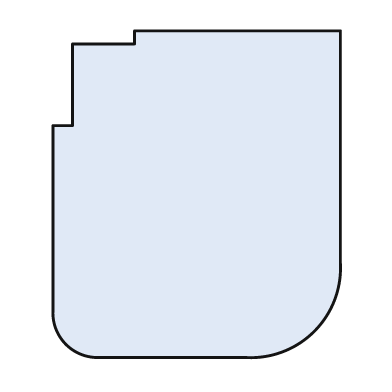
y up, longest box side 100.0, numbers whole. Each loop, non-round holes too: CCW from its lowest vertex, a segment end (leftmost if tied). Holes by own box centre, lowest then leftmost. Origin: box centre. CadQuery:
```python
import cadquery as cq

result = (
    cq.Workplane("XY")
    .moveTo(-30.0, -50.0)
    .lineTo(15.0, -50.0)
    .threePointArc((36.0, -42.0), (44.0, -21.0))
    .lineTo(44.0, 50.0)
    .lineTo(-19.0, 50.0)
    .lineTo(-19.0, 46.0)
    .lineTo(-38.0, 46.0)
    .lineTo(-38.0, 21.0)
    .lineTo(-44.0, 21.0)
    .lineTo(-44.0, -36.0)
    .threePointArc((-40.0, -46.0), (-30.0, -50.0))
    .close()
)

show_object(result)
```